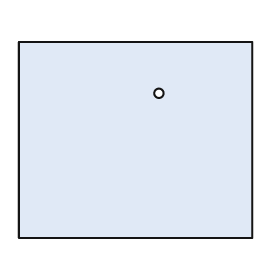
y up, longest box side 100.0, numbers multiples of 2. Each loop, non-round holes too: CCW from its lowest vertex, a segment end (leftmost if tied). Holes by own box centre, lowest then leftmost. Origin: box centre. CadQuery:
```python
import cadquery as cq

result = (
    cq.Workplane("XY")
    .moveTo(-50.0, -42.0)
    .lineTo(50.0, -42.0)
    .lineTo(50.0, 42.0)
    .lineTo(-50.0, 42.0)
    .close()
    .moveTo(10.0, 20.0)
    .circle(2.0)
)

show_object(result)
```